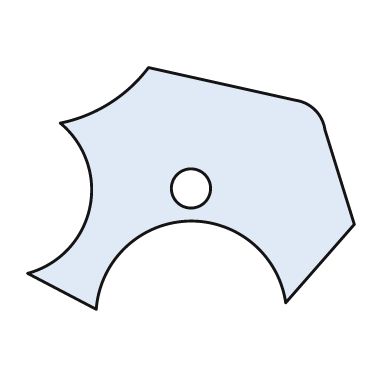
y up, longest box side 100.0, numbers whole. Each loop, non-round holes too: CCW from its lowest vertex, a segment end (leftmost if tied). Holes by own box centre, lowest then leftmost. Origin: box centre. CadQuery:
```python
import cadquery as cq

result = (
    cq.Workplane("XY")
    .moveTo(-29.0, -37.0)
    .threePointArc((-1.0, -10.0), (29.0, -35.0))
    .lineTo(50.0, -11.0)
    .lineTo(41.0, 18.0)
    .threePointArc((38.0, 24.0), (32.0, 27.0))
    .lineTo(-13.0, 37.0)
    .threePointArc((-25.0, 26.0), (-40.0, 20.0))
    .threePointArc((-31.0, -6.0), (-50.0, -26.0))
    .close()
    .moveTo(0.0, 0.0)
    .circle(6.0)
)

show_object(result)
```